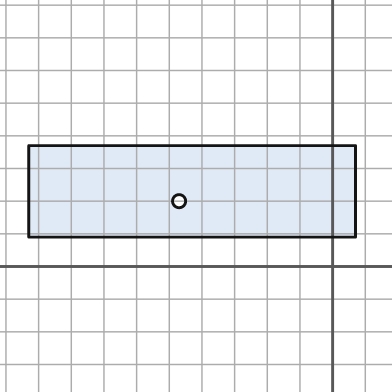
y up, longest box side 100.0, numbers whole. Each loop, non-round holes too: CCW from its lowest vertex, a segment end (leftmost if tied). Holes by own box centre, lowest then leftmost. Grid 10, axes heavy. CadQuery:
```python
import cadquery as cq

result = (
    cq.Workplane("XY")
    .moveTo(-93.0, 9.0)
    .lineTo(7.0, 9.0)
    .lineTo(7.0, 37.0)
    .lineTo(-93.0, 37.0)
    .close()
    .moveTo(-47.0, 20.0)
    .circle(2.0)
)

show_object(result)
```